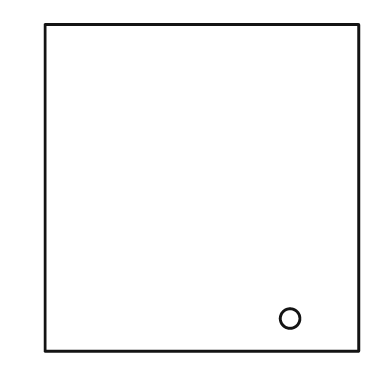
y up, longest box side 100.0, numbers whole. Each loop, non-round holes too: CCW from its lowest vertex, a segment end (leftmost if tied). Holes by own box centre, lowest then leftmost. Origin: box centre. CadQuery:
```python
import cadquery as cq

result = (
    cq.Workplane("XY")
    .moveTo(-48.0, -50.0)
    .lineTo(48.0, -50.0)
    .lineTo(48.0, 50.0)
    .lineTo(-48.0, 50.0)
    .close()
    .moveTo(27.0, -40.0)
    .circle(3.0)
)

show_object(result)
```